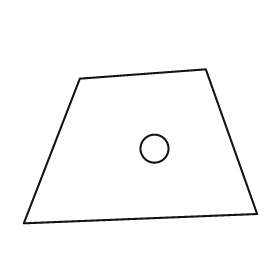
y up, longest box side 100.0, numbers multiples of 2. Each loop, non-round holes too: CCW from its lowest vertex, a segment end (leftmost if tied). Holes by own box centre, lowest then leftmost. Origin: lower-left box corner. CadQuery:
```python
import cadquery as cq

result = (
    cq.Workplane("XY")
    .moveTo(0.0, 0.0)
    .lineTo(100.0, 4.0)
    .lineTo(78.0, 66.0)
    .lineTo(24.0, 62.0)
    .close()
    .moveTo(56.0, 32.0)
    .circle(6.0)
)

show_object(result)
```